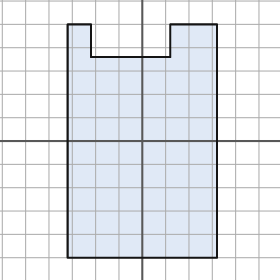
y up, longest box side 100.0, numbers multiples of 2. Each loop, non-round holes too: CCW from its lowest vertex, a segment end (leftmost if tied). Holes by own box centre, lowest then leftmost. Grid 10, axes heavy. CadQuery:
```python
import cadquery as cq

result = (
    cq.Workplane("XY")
    .moveTo(-32.0, -50.0)
    .lineTo(32.0, -50.0)
    .lineTo(32.0, 50.0)
    .lineTo(12.0, 50.0)
    .lineTo(12.0, 36.0)
    .lineTo(-22.0, 36.0)
    .lineTo(-22.0, 50.0)
    .lineTo(-32.0, 50.0)
    .close()
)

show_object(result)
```